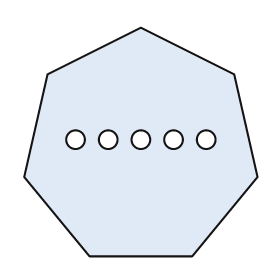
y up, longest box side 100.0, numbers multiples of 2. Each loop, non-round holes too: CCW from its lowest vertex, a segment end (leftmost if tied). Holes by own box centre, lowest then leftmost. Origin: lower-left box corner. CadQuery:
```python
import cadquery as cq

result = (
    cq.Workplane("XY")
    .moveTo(28.0, 0.0)
    .lineTo(72.0, 0.0)
    .lineTo(100.0, 34.0)
    .lineTo(90.0, 78.0)
    .lineTo(50.0, 98.0)
    .lineTo(10.0, 78.0)
    .lineTo(0.0, 34.0)
    .close()
    .moveTo(22.0, 50.0)
    .circle(4.0)
    .moveTo(36.0, 50.0)
    .circle(4.0)
    .moveTo(50.0, 50.0)
    .circle(4.0)
    .moveTo(64.0, 50.0)
    .circle(4.0)
    .moveTo(78.0, 50.0)
    .circle(4.0)
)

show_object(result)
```